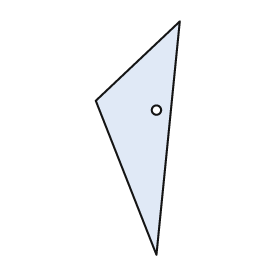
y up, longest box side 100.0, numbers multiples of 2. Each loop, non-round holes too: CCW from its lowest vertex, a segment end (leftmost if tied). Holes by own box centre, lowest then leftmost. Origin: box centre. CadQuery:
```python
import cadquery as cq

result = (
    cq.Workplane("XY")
    .moveTo(8.0, -50.0)
    .lineTo(18.0, 50.0)
    .lineTo(-18.0, 16.0)
    .close()
    .moveTo(8.0, 12.0)
    .circle(2.0)
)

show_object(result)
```